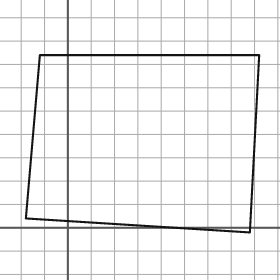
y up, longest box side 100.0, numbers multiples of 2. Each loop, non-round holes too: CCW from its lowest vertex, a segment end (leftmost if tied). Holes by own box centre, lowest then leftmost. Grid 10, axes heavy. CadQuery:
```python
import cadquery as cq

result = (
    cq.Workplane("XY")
    .moveTo(78.0, -2.0)
    .lineTo(82.0, 74.0)
    .lineTo(-12.0, 74.0)
    .lineTo(-18.0, 4.0)
    .close()
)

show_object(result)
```